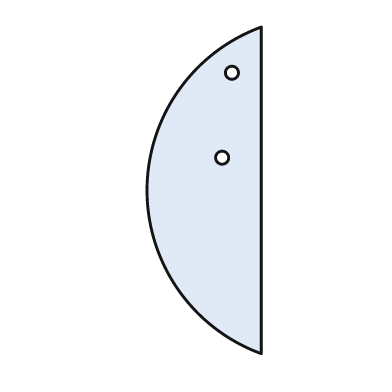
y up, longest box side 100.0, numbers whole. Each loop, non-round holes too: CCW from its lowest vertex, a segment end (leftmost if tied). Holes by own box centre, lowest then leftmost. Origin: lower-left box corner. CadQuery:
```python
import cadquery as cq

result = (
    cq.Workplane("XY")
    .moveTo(35.0, 0.0)
    .lineTo(35.0, 100.0)
    .threePointArc((0.0, 50.0), (35.0, 0.0))
    .close()
    .moveTo(23.0, 60.0)
    .circle(2.0)
    .moveTo(26.0, 86.0)
    .circle(2.0)
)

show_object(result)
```